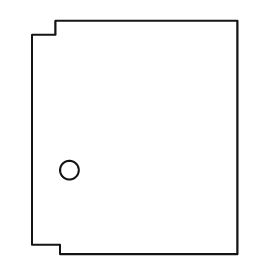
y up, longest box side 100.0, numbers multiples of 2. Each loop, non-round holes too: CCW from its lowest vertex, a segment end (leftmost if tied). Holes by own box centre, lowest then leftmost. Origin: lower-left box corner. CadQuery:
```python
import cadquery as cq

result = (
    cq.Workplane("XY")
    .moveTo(12.0, 0.0)
    .lineTo(88.0, 0.0)
    .lineTo(88.0, 100.0)
    .lineTo(10.0, 100.0)
    .lineTo(10.0, 94.0)
    .lineTo(0.0, 94.0)
    .lineTo(0.0, 4.0)
    .lineTo(12.0, 4.0)
    .close()
    .moveTo(16.0, 36.0)
    .circle(4.0)
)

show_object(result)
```